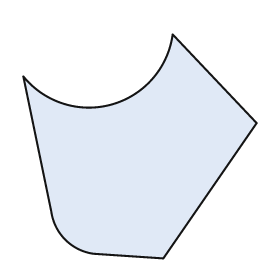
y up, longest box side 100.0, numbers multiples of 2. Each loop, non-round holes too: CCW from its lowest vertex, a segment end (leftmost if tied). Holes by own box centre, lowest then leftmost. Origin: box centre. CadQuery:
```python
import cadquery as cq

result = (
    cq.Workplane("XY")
    .moveTo(10.0, -48.0)
    .lineTo(50.0, 10.0)
    .lineTo(14.0, 48.0)
    .threePointArc((-12.0, 18.0), (-50.0, 30.0))
    .lineTo(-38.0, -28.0)
    .threePointArc((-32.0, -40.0), (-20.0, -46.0))
    .close()
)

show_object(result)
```